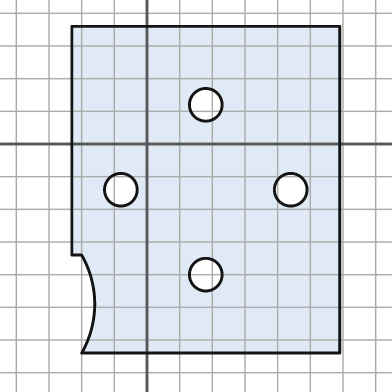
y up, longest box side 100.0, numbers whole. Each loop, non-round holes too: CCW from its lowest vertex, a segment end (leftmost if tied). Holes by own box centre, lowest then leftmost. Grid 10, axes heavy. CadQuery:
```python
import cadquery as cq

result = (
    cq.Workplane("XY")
    .moveTo(-20.0, -64.0)
    .lineTo(59.0, -64.0)
    .lineTo(59.0, 36.0)
    .lineTo(-23.0, 36.0)
    .lineTo(-23.0, -34.0)
    .lineTo(-20.0, -34.0)
    .threePointArc((-16.0, -49.0), (-20.0, -64.0))
    .close()
    .moveTo(18.0, -40.0)
    .circle(5.0)
    .moveTo(-8.0, -14.0)
    .circle(5.0)
    .moveTo(44.0, -14.0)
    .circle(5.0)
    .moveTo(18.0, 12.0)
    .circle(5.0)
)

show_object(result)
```